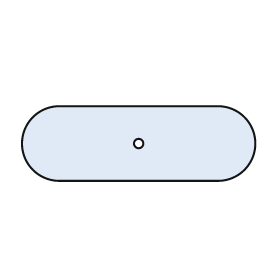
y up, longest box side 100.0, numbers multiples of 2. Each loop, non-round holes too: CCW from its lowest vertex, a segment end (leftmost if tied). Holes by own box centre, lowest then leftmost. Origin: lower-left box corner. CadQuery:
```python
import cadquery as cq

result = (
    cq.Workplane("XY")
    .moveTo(16.0, 0.0)
    .lineTo(84.0, 0.0)
    .threePointArc((100.0, 16.0), (84.0, 32.0))
    .lineTo(16.0, 32.0)
    .threePointArc((0.0, 16.0), (16.0, 0.0))
    .close()
    .moveTo(50.0, 16.0)
    .circle(2.0)
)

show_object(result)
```